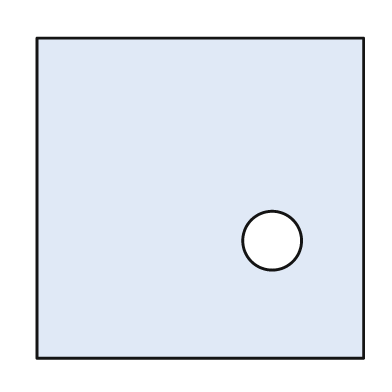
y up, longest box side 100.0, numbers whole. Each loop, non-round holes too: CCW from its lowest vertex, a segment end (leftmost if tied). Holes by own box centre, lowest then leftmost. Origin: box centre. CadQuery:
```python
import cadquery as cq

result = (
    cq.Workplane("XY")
    .moveTo(-50.0, -49.0)
    .lineTo(50.0, -49.0)
    .lineTo(50.0, 49.0)
    .lineTo(-50.0, 49.0)
    .close()
    .moveTo(22.0, -13.0)
    .circle(9.0)
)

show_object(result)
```